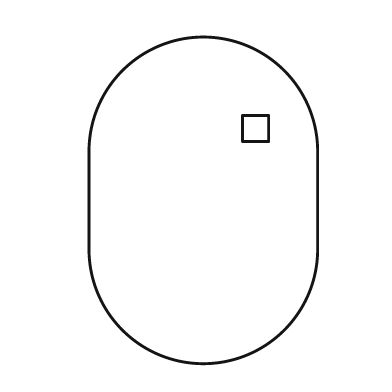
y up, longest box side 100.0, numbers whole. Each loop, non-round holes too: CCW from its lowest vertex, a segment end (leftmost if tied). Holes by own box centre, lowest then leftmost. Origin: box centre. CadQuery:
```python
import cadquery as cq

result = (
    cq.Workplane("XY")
    .moveTo(-35.0, -15.0)
    .threePointArc((0.0, -50.0), (35.0, -15.0))
    .lineTo(35.0, 15.0)
    .threePointArc((0.0, 50.0), (-35.0, 15.0))
    .close()
    .moveTo(12.0, 18.0)
    .lineTo(20.0, 18.0)
    .lineTo(20.0, 26.0)
    .lineTo(12.0, 26.0)
    .close()
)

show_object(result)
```